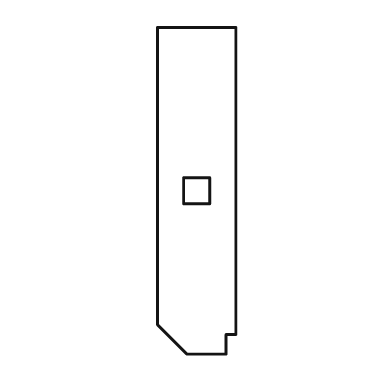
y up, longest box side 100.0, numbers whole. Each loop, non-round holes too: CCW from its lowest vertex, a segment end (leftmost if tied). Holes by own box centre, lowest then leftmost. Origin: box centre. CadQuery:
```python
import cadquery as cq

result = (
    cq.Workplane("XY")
    .moveTo(-3.0, -50.0)
    .lineTo(9.0, -50.0)
    .lineTo(9.0, -44.0)
    .lineTo(12.0, -44.0)
    .lineTo(12.0, 50.0)
    .lineTo(-12.0, 50.0)
    .lineTo(-12.0, -41.0)
    .close()
    .moveTo(-4.0, -4.0)
    .lineTo(4.0, -4.0)
    .lineTo(4.0, 4.0)
    .lineTo(-4.0, 4.0)
    .close()
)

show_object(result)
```